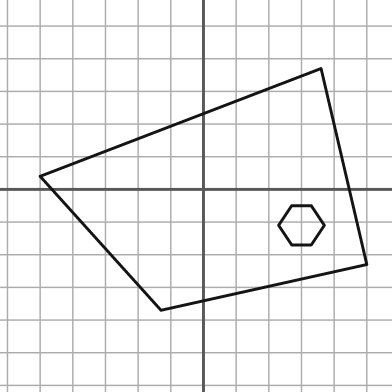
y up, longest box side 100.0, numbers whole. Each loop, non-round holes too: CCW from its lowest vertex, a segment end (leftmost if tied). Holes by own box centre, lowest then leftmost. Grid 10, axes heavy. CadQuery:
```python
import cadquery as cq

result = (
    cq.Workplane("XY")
    .moveTo(-13.0, -37.0)
    .lineTo(50.0, -23.0)
    .lineTo(36.0, 37.0)
    .lineTo(-50.0, 4.0)
    .close()
    .moveTo(27.0, -17.0)
    .lineTo(33.0, -17.0)
    .lineTo(37.0, -11.0)
    .lineTo(33.0, -5.0)
    .lineTo(27.0, -5.0)
    .lineTo(23.0, -11.0)
    .close()
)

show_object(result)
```